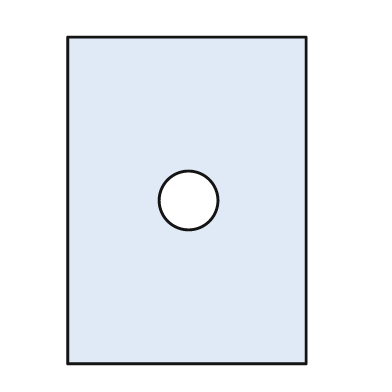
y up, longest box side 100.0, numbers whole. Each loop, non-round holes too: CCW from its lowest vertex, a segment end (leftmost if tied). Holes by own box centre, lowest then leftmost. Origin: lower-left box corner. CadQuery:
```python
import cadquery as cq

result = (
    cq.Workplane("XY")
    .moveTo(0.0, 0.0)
    .lineTo(73.0, 0.0)
    .lineTo(73.0, 100.0)
    .lineTo(0.0, 100.0)
    .close()
    .moveTo(37.0, 50.0)
    .circle(9.0)
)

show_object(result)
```